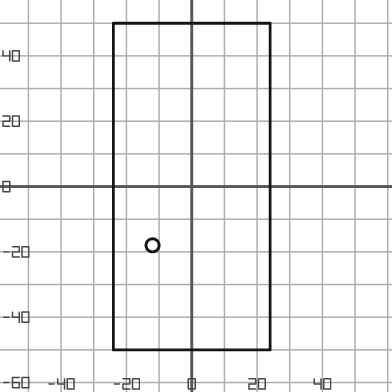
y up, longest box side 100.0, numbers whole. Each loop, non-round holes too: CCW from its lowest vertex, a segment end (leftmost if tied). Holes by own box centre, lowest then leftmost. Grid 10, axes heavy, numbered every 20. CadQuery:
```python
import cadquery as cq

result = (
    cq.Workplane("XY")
    .moveTo(-24.0, -50.0)
    .lineTo(24.0, -50.0)
    .lineTo(24.0, 50.0)
    .lineTo(-24.0, 50.0)
    .close()
    .moveTo(-12.0, -18.0)
    .circle(2.0)
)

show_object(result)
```